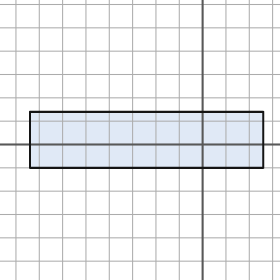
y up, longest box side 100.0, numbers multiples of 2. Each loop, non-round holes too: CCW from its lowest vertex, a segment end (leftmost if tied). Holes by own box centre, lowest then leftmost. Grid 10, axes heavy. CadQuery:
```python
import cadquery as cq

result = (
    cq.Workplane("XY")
    .moveTo(-74.0, -10.0)
    .lineTo(26.0, -10.0)
    .lineTo(26.0, 14.0)
    .lineTo(-74.0, 14.0)
    .close()
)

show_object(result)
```